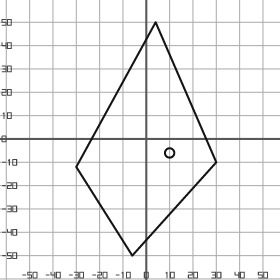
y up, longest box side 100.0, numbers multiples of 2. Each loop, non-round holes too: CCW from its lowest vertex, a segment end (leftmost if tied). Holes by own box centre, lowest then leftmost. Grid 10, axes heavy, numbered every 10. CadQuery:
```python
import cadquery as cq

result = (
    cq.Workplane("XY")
    .moveTo(-6.0, -50.0)
    .lineTo(30.0, -10.0)
    .lineTo(4.0, 50.0)
    .lineTo(-30.0, -12.0)
    .close()
    .moveTo(10.0, -6.0)
    .circle(2.0)
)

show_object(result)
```